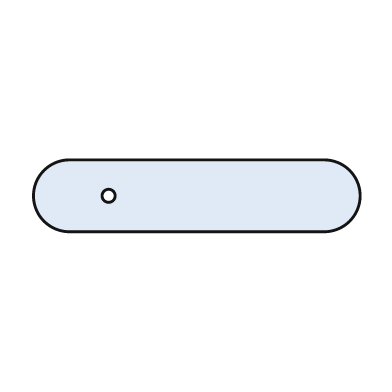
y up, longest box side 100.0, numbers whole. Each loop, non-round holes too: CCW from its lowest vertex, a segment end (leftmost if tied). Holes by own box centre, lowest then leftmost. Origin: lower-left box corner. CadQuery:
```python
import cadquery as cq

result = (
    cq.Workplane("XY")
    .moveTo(11.0, 0.0)
    .lineTo(89.0, 0.0)
    .threePointArc((100.0, 11.0), (89.0, 22.0))
    .lineTo(11.0, 22.0)
    .threePointArc((0.0, 11.0), (11.0, 0.0))
    .close()
    .moveTo(23.0, 11.0)
    .circle(2.0)
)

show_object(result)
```